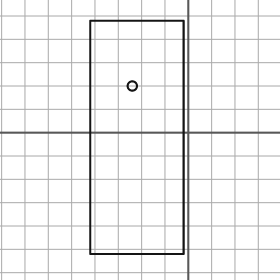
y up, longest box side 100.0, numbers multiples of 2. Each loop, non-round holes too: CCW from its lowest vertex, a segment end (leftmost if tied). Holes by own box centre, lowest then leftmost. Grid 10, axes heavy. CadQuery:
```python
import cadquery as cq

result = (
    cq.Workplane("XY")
    .moveTo(-42.0, -52.0)
    .lineTo(-2.0, -52.0)
    .lineTo(-2.0, 48.0)
    .lineTo(-42.0, 48.0)
    .close()
    .moveTo(-24.0, 20.0)
    .circle(2.0)
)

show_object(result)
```